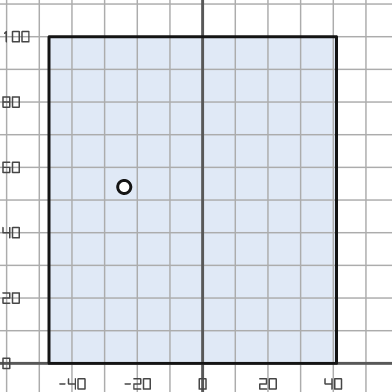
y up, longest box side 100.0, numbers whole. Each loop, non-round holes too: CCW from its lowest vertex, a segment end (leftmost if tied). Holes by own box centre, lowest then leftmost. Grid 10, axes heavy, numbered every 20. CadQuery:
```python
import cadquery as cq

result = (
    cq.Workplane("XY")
    .moveTo(-47.0, 0.0)
    .lineTo(41.0, 0.0)
    .lineTo(41.0, 100.0)
    .lineTo(-47.0, 100.0)
    .close()
    .moveTo(-24.0, 54.0)
    .circle(2.0)
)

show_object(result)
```